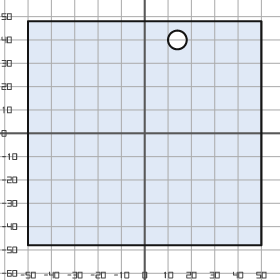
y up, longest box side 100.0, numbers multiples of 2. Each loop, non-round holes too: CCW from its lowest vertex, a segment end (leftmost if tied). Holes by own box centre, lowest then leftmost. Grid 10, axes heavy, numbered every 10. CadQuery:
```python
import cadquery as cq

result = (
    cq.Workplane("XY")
    .moveTo(-50.0, -48.0)
    .lineTo(50.0, -48.0)
    .lineTo(50.0, 48.0)
    .lineTo(-50.0, 48.0)
    .close()
    .moveTo(14.0, 40.0)
    .circle(4.0)
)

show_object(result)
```